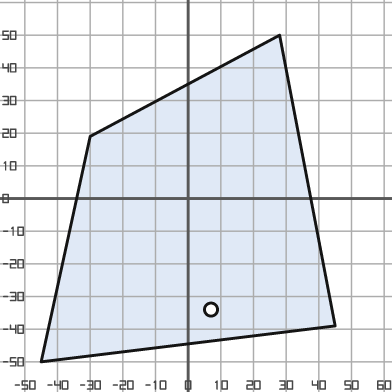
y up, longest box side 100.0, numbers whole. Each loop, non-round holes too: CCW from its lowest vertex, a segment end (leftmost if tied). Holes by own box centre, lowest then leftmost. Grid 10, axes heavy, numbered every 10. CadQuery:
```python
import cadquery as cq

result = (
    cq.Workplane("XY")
    .moveTo(-45.0, -50.0)
    .lineTo(45.0, -39.0)
    .lineTo(28.0, 50.0)
    .lineTo(-30.0, 19.0)
    .close()
    .moveTo(7.0, -34.0)
    .circle(2.0)
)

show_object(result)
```